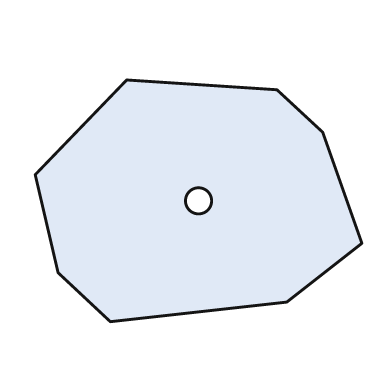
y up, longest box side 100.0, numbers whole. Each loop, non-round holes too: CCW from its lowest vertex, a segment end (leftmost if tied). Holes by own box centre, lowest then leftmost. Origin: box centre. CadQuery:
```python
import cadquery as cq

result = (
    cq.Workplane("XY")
    .moveTo(-27.0, -37.0)
    .lineTo(27.0, -31.0)
    .lineTo(50.0, -13.0)
    .lineTo(38.0, 21.0)
    .lineTo(24.0, 34.0)
    .lineTo(-22.0, 37.0)
    .lineTo(-50.0, 8.0)
    .lineTo(-43.0, -22.0)
    .close()
    .moveTo(0.0, 0.0)
    .circle(4.0)
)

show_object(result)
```